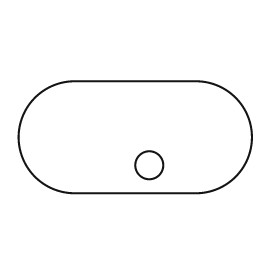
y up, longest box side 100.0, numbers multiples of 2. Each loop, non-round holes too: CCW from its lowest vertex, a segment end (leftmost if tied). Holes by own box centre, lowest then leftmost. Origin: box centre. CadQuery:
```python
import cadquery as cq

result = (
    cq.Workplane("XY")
    .moveTo(-26.0, -24.0)
    .lineTo(26.0, -24.0)
    .threePointArc((50.0, 0.0), (26.0, 24.0))
    .lineTo(-26.0, 24.0)
    .threePointArc((-50.0, 0.0), (-26.0, -24.0))
    .close()
    .moveTo(6.0, -12.0)
    .circle(6.0)
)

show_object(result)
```